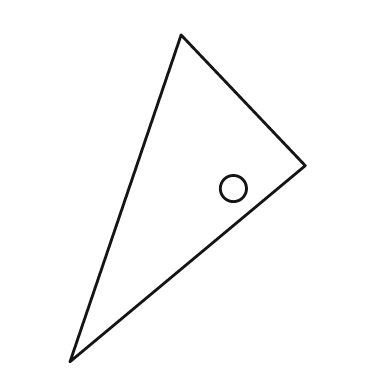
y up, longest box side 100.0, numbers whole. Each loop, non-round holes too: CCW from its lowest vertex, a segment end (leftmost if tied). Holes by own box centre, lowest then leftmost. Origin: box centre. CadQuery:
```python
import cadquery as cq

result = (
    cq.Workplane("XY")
    .moveTo(-36.0, -50.0)
    .lineTo(36.0, 10.0)
    .lineTo(-2.0, 50.0)
    .close()
    .moveTo(14.0, 3.0)
    .circle(4.0)
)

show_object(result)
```